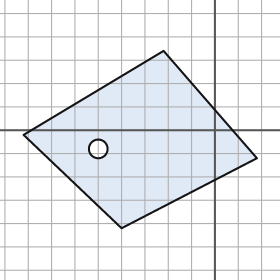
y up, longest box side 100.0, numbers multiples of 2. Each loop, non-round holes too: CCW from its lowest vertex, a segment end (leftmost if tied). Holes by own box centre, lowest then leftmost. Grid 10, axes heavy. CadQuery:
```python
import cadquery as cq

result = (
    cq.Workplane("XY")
    .moveTo(-40.0, -42.0)
    .lineTo(18.0, -12.0)
    .lineTo(-22.0, 34.0)
    .lineTo(-82.0, -2.0)
    .close()
    .moveTo(-50.0, -8.0)
    .circle(4.0)
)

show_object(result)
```